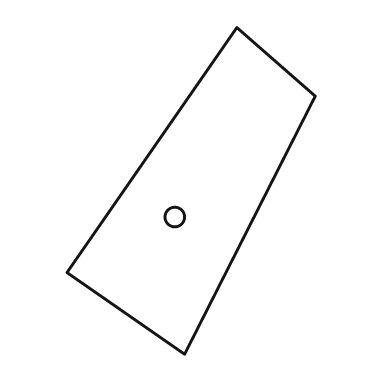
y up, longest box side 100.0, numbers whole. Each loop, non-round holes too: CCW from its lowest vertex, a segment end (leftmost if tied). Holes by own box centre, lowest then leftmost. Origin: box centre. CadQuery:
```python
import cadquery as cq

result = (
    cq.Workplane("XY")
    .moveTo(-2.0, -50.0)
    .lineTo(38.0, 29.0)
    .lineTo(14.0, 50.0)
    .lineTo(-38.0, -25.0)
    .close()
    .moveTo(-5.0, -8.0)
    .circle(3.0)
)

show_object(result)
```